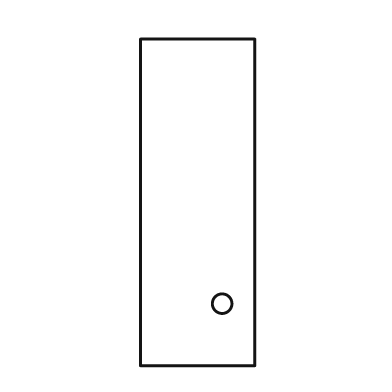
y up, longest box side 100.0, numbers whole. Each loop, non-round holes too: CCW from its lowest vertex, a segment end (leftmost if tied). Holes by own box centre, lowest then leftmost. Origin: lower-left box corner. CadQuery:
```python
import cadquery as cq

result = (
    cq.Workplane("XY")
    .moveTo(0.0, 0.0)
    .lineTo(35.0, 0.0)
    .lineTo(35.0, 100.0)
    .lineTo(0.0, 100.0)
    .close()
    .moveTo(25.0, 19.0)
    .circle(3.0)
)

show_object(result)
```